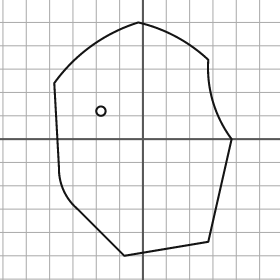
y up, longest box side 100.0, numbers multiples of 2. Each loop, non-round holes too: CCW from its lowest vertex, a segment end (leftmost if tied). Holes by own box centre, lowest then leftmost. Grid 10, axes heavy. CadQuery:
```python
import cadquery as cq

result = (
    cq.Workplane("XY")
    .moveTo(-8.0, -50.0)
    .lineTo(28.0, -44.0)
    .lineTo(38.0, 0.0)
    .threePointArc((30.0, 16.0), (28.0, 34.0))
    .threePointArc((14.0, 44.0), (-2.0, 50.0))
    .threePointArc((-22.0, 40.0), (-38.0, 24.0))
    .lineTo(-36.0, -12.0)
    .threePointArc((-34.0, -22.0), (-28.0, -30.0))
    .close()
    .moveTo(-18.0, 12.0)
    .circle(2.0)
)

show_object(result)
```